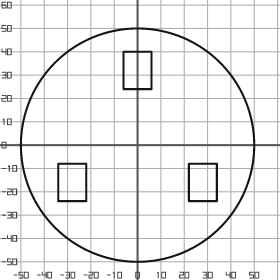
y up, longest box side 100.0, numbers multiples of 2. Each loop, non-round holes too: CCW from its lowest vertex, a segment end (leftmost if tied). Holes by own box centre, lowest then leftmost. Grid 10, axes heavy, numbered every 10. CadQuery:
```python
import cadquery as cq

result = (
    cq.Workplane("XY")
    .moveTo(0.0, 0.0)
    .circle(50.0)
    .moveTo(-34.0, -24.0)
    .lineTo(-22.0, -24.0)
    .lineTo(-22.0, -8.0)
    .lineTo(-34.0, -8.0)
    .close()
    .moveTo(22.0, -24.0)
    .lineTo(34.0, -24.0)
    .lineTo(34.0, -8.0)
    .lineTo(22.0, -8.0)
    .close()
    .moveTo(-6.0, 24.0)
    .lineTo(6.0, 24.0)
    .lineTo(6.0, 40.0)
    .lineTo(-6.0, 40.0)
    .close()
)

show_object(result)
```